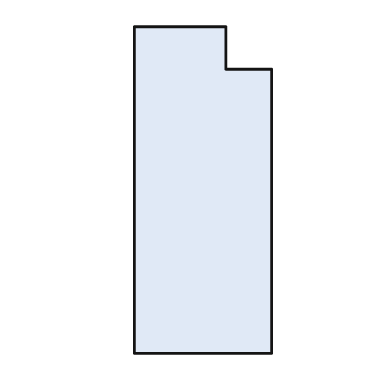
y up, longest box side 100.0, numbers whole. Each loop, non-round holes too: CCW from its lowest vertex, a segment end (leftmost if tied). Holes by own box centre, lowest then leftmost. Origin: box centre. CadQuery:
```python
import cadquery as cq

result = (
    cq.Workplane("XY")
    .moveTo(-21.0, -50.0)
    .lineTo(21.0, -50.0)
    .lineTo(21.0, 37.0)
    .lineTo(7.0, 37.0)
    .lineTo(7.0, 50.0)
    .lineTo(-21.0, 50.0)
    .close()
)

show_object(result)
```